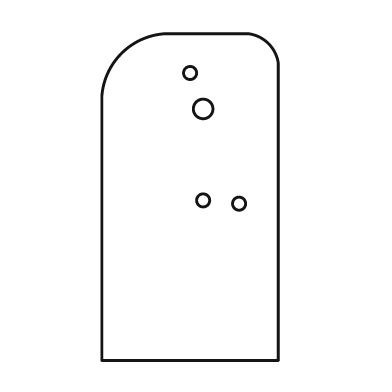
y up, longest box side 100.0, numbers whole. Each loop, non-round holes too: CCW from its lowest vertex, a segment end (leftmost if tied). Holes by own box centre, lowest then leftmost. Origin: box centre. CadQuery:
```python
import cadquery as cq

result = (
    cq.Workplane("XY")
    .moveTo(-27.0, -50.0)
    .lineTo(27.0, -50.0)
    .lineTo(27.0, 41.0)
    .threePointArc((24.0, 47.0), (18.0, 50.0))
    .lineTo(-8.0, 50.0)
    .threePointArc((-21.0, 44.0), (-27.0, 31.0))
    .close()
    .moveTo(15.0, -2.0)
    .circle(2.0)
    .moveTo(4.0, -1.0)
    .circle(2.0)
    .moveTo(4.0, 27.0)
    .circle(3.0)
    .moveTo(0.0, 38.0)
    .circle(2.0)
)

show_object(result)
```